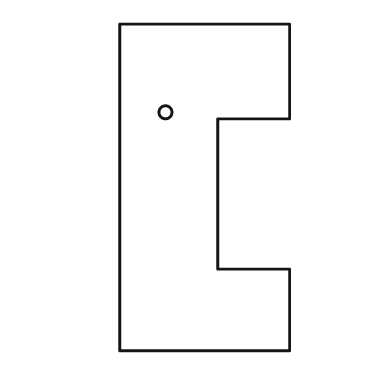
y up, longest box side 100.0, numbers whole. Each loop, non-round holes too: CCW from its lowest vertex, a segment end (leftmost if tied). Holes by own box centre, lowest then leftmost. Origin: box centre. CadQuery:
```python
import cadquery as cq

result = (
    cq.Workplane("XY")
    .moveTo(-26.0, -50.0)
    .lineTo(26.0, -50.0)
    .lineTo(26.0, -25.0)
    .lineTo(4.0, -25.0)
    .lineTo(4.0, 21.0)
    .lineTo(26.0, 21.0)
    .lineTo(26.0, 50.0)
    .lineTo(-26.0, 50.0)
    .close()
    .moveTo(-12.0, 23.0)
    .circle(2.0)
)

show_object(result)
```